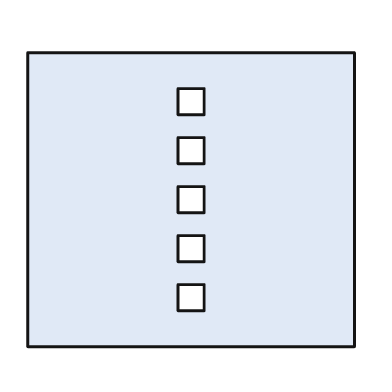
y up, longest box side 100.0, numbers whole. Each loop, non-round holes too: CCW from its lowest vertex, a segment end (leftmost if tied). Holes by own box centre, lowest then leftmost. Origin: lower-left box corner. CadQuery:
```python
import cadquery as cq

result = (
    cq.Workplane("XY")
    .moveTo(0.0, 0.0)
    .lineTo(100.0, 0.0)
    .lineTo(100.0, 90.0)
    .lineTo(0.0, 90.0)
    .close()
    .moveTo(46.0, 11.0)
    .lineTo(54.0, 11.0)
    .lineTo(54.0, 19.0)
    .lineTo(46.0, 19.0)
    .close()
    .moveTo(46.0, 26.0)
    .lineTo(54.0, 26.0)
    .lineTo(54.0, 34.0)
    .lineTo(46.0, 34.0)
    .close()
    .moveTo(46.0, 41.0)
    .lineTo(54.0, 41.0)
    .lineTo(54.0, 49.0)
    .lineTo(46.0, 49.0)
    .close()
    .moveTo(46.0, 56.0)
    .lineTo(54.0, 56.0)
    .lineTo(54.0, 64.0)
    .lineTo(46.0, 64.0)
    .close()
    .moveTo(46.0, 71.0)
    .lineTo(54.0, 71.0)
    .lineTo(54.0, 79.0)
    .lineTo(46.0, 79.0)
    .close()
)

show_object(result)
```